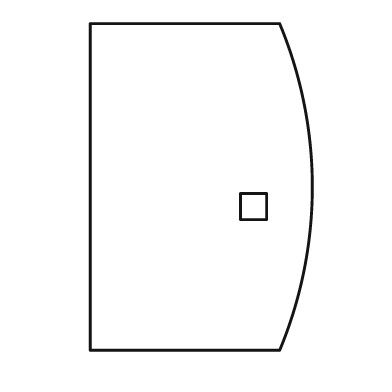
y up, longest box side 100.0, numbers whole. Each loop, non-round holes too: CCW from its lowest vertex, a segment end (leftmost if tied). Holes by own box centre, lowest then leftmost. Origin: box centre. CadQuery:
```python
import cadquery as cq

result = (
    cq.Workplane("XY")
    .moveTo(-34.0, -50.0)
    .lineTo(24.0, -50.0)
    .threePointArc((34.0, 0.0), (24.0, 50.0))
    .lineTo(-34.0, 50.0)
    .close()
    .moveTo(12.0, -10.0)
    .lineTo(20.0, -10.0)
    .lineTo(20.0, -2.0)
    .lineTo(12.0, -2.0)
    .close()
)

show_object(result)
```